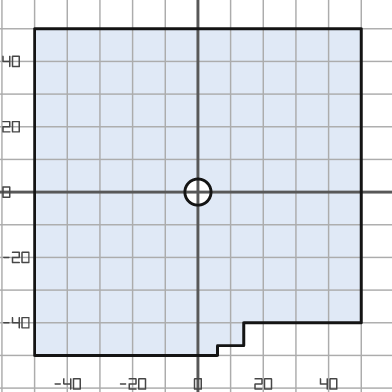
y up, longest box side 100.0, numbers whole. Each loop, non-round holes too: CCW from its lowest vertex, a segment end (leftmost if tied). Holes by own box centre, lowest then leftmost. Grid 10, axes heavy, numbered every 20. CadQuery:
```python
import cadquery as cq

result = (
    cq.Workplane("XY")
    .moveTo(-50.0, -50.0)
    .lineTo(6.0, -50.0)
    .lineTo(6.0, -47.0)
    .lineTo(14.0, -47.0)
    .lineTo(14.0, -40.0)
    .lineTo(50.0, -40.0)
    .lineTo(50.0, 50.0)
    .lineTo(-50.0, 50.0)
    .close()
    .moveTo(0.0, 0.0)
    .circle(4.0)
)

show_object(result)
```